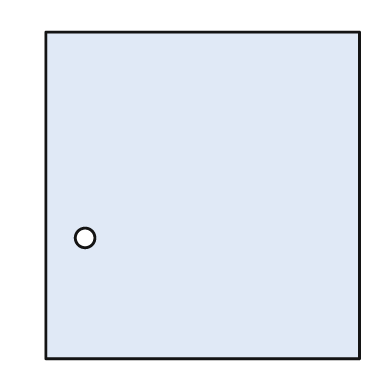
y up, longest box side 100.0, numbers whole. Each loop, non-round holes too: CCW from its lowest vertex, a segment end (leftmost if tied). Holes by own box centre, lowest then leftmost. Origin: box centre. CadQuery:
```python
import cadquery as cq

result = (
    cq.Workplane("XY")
    .moveTo(-48.0, -50.0)
    .lineTo(48.0, -50.0)
    .lineTo(48.0, 50.0)
    .lineTo(-48.0, 50.0)
    .close()
    .moveTo(-36.0, -13.0)
    .circle(3.0)
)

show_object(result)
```